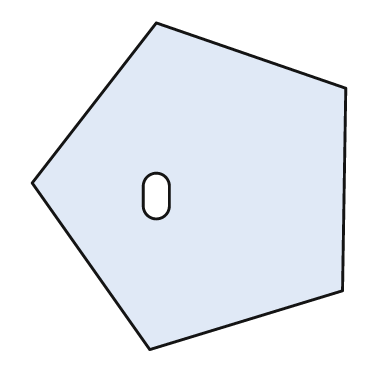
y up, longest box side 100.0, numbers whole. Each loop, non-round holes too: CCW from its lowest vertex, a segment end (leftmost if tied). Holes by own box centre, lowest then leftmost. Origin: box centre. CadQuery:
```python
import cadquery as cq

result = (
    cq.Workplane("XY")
    .moveTo(-12.0, -50.0)
    .lineTo(47.0, -32.0)
    .lineTo(48.0, 30.0)
    .lineTo(-10.0, 50.0)
    .lineTo(-48.0, 1.0)
    .close()
    .moveTo(-14.0, -6.0)
    .threePointArc((-10.0, -10.0), (-6.0, -6.0))
    .lineTo(-6.0, 0.0)
    .threePointArc((-10.0, 4.0), (-14.0, 0.0))
    .close()
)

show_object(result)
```